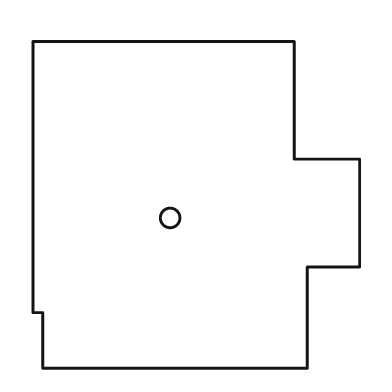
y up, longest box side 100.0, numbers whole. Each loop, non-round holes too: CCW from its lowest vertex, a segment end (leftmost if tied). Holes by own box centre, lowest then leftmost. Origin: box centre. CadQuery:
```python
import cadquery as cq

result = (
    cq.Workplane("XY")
    .moveTo(-47.0, -50.0)
    .lineTo(34.0, -50.0)
    .lineTo(34.0, -19.0)
    .lineTo(50.0, -19.0)
    .lineTo(50.0, 14.0)
    .lineTo(30.0, 14.0)
    .lineTo(30.0, 50.0)
    .lineTo(-50.0, 50.0)
    .lineTo(-50.0, -33.0)
    .lineTo(-47.0, -33.0)
    .close()
    .moveTo(-8.0, -4.0)
    .circle(3.0)
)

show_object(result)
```